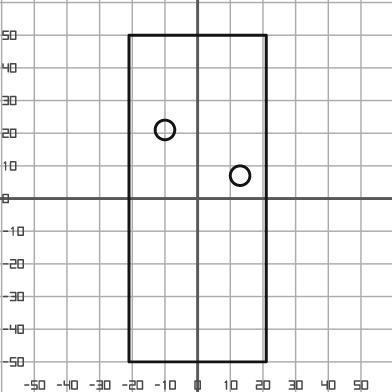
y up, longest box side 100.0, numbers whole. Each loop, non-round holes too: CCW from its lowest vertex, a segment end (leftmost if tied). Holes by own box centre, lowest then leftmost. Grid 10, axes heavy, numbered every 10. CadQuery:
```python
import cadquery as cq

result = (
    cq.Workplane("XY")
    .moveTo(-21.0, -50.0)
    .lineTo(21.0, -50.0)
    .lineTo(21.0, 50.0)
    .lineTo(-21.0, 50.0)
    .close()
    .moveTo(13.0, 7.0)
    .circle(3.0)
    .moveTo(-10.0, 21.0)
    .circle(3.0)
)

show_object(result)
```